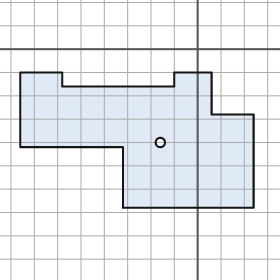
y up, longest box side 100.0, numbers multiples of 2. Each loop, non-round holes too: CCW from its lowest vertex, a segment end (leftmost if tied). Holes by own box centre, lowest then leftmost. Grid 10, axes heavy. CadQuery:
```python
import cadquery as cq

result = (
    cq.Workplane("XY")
    .moveTo(-32.0, -68.0)
    .lineTo(24.0, -68.0)
    .lineTo(24.0, -28.0)
    .lineTo(6.0, -28.0)
    .lineTo(6.0, -10.0)
    .lineTo(-10.0, -10.0)
    .lineTo(-10.0, -16.0)
    .lineTo(-58.0, -16.0)
    .lineTo(-58.0, -10.0)
    .lineTo(-76.0, -10.0)
    .lineTo(-76.0, -42.0)
    .lineTo(-32.0, -42.0)
    .close()
    .moveTo(-16.0, -40.0)
    .circle(2.0)
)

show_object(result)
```